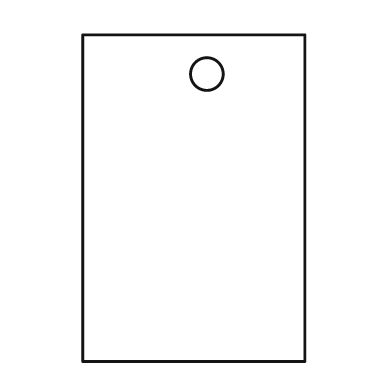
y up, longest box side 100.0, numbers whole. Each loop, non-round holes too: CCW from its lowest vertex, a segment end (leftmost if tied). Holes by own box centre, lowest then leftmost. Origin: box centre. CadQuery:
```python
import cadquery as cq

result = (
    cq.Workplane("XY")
    .moveTo(-34.0, -50.0)
    .lineTo(34.0, -50.0)
    .lineTo(34.0, 50.0)
    .lineTo(-34.0, 50.0)
    .close()
    .moveTo(4.0, 38.0)
    .circle(5.0)
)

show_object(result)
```